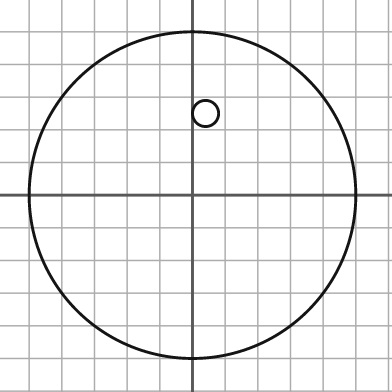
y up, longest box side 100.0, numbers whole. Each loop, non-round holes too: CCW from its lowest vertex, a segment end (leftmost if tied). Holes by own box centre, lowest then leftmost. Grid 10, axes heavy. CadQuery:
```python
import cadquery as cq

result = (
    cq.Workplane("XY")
    .moveTo(0.0, 0.0)
    .circle(50.0)
    .moveTo(4.0, 25.0)
    .circle(4.0)
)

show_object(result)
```